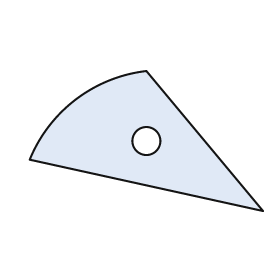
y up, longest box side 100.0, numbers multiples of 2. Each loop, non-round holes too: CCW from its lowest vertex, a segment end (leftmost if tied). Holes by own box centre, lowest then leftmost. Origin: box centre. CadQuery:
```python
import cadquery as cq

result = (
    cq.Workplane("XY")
    .moveTo(50.0, -30.0)
    .lineTo(0.0, 30.0)
    .threePointArc((-30.0, 18.0), (-50.0, -8.0))
    .close()
    .moveTo(0.0, 0.0)
    .circle(6.0)
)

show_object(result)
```